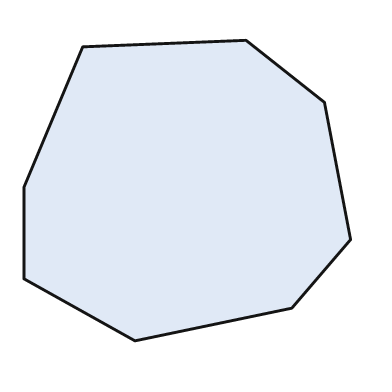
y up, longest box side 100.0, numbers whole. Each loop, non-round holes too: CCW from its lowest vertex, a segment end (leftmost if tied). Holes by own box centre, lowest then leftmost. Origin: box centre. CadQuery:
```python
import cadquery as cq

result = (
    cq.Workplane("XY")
    .moveTo(-16.0, -46.0)
    .lineTo(32.0, -36.0)
    .lineTo(50.0, -15.0)
    .lineTo(42.0, 27.0)
    .lineTo(18.0, 46.0)
    .lineTo(-32.0, 44.0)
    .lineTo(-50.0, 1.0)
    .lineTo(-50.0, -27.0)
    .close()
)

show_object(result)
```